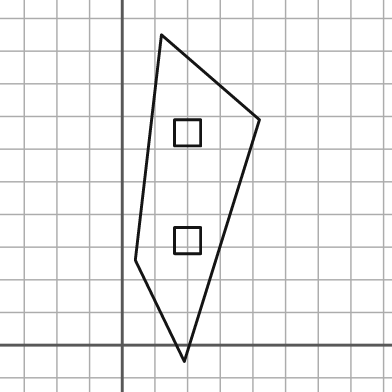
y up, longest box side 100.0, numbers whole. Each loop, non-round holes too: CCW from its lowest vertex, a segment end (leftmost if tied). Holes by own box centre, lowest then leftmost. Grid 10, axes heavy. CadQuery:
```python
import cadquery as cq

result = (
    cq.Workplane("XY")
    .moveTo(19.0, -5.0)
    .lineTo(42.0, 69.0)
    .lineTo(12.0, 95.0)
    .lineTo(4.0, 26.0)
    .close()
    .moveTo(16.0, 28.0)
    .lineTo(24.0, 28.0)
    .lineTo(24.0, 36.0)
    .lineTo(16.0, 36.0)
    .close()
    .moveTo(16.0, 61.0)
    .lineTo(24.0, 61.0)
    .lineTo(24.0, 69.0)
    .lineTo(16.0, 69.0)
    .close()
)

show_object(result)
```